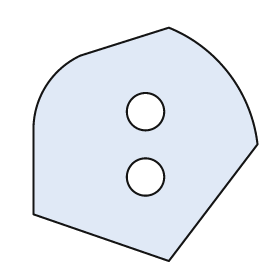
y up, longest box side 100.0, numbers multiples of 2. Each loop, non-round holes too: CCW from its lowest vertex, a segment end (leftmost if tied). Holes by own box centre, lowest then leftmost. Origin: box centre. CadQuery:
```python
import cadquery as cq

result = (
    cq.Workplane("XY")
    .moveTo(10.0, -50.0)
    .lineTo(48.0, 0.0)
    .threePointArc((36.0, 30.0), (10.0, 50.0))
    .lineTo(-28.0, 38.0)
    .threePointArc((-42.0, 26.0), (-48.0, 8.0))
    .lineTo(-48.0, -30.0)
    .close()
    .moveTo(0.0, -14.0)
    .circle(8.0)
    .moveTo(0.0, 14.0)
    .circle(8.0)
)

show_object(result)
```